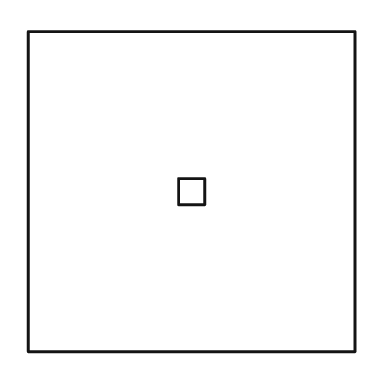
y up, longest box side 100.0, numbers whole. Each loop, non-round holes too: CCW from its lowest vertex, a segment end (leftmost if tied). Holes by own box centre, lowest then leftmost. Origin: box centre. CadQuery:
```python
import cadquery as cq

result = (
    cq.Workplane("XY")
    .moveTo(-50.0, -49.0)
    .lineTo(50.0, -49.0)
    .lineTo(50.0, 49.0)
    .lineTo(-50.0, 49.0)
    .close()
    .moveTo(-4.0, -4.0)
    .lineTo(4.0, -4.0)
    .lineTo(4.0, 4.0)
    .lineTo(-4.0, 4.0)
    .close()
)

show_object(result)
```